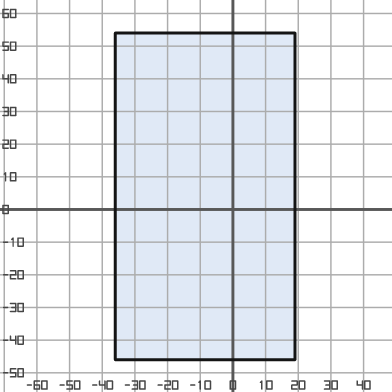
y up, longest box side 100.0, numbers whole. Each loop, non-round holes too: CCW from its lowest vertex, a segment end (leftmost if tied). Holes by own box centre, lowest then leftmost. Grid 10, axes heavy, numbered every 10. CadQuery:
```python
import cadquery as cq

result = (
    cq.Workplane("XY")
    .moveTo(-36.0, -46.0)
    .lineTo(19.0, -46.0)
    .lineTo(19.0, 54.0)
    .lineTo(-36.0, 54.0)
    .close()
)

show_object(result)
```